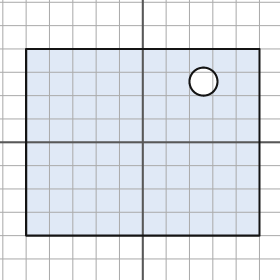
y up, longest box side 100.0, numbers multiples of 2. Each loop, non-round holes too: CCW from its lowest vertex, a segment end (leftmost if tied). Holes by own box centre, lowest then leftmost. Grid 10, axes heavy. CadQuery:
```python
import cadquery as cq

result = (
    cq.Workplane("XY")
    .moveTo(-50.0, -40.0)
    .lineTo(50.0, -40.0)
    .lineTo(50.0, 40.0)
    .lineTo(-50.0, 40.0)
    .close()
    .moveTo(26.0, 26.0)
    .circle(6.0)
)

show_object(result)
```